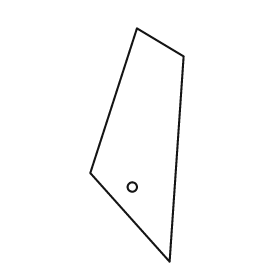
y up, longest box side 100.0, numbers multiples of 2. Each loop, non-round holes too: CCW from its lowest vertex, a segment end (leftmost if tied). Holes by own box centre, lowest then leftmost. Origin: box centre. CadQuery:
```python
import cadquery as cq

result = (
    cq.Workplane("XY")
    .moveTo(14.0, -50.0)
    .lineTo(20.0, 38.0)
    .lineTo(0.0, 50.0)
    .lineTo(-20.0, -12.0)
    .close()
    .moveTo(-2.0, -18.0)
    .circle(2.0)
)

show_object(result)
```